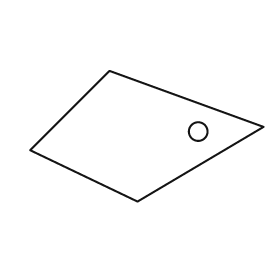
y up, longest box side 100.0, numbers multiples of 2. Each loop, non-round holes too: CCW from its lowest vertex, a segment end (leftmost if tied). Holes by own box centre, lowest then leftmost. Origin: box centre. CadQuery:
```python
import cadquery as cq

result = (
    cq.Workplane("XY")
    .moveTo(-4.0, -28.0)
    .lineTo(50.0, 4.0)
    .lineTo(-16.0, 28.0)
    .lineTo(-50.0, -6.0)
    .close()
    .moveTo(22.0, 2.0)
    .circle(4.0)
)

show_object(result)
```